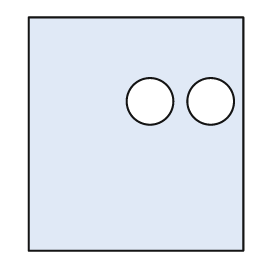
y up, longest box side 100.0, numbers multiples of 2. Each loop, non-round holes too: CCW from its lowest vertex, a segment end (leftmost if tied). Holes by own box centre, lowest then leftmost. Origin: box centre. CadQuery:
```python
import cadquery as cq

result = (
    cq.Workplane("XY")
    .moveTo(-46.0, -50.0)
    .lineTo(46.0, -50.0)
    .lineTo(46.0, 50.0)
    .lineTo(-46.0, 50.0)
    .close()
    .moveTo(6.0, 14.0)
    .circle(10.0)
    .moveTo(32.0, 14.0)
    .circle(10.0)
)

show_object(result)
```